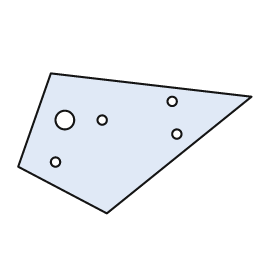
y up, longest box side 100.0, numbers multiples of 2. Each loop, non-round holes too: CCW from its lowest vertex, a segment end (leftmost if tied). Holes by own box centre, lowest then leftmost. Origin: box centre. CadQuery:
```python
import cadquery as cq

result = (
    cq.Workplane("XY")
    .moveTo(-12.0, -30.0)
    .lineTo(50.0, 20.0)
    .lineTo(-36.0, 30.0)
    .lineTo(-50.0, -10.0)
    .close()
    .moveTo(-34.0, -8.0)
    .circle(2.0)
    .moveTo(18.0, 4.0)
    .circle(2.0)
    .moveTo(-30.0, 10.0)
    .circle(4.0)
    .moveTo(-14.0, 10.0)
    .circle(2.0)
    .moveTo(16.0, 18.0)
    .circle(2.0)
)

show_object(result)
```